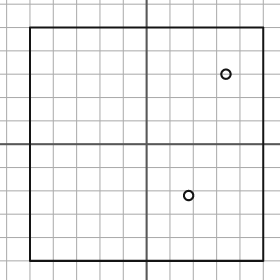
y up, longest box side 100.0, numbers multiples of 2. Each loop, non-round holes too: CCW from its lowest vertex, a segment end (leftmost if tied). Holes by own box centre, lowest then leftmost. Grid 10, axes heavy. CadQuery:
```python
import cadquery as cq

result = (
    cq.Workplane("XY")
    .moveTo(-50.0, -50.0)
    .lineTo(50.0, -50.0)
    .lineTo(50.0, 50.0)
    .lineTo(-50.0, 50.0)
    .close()
    .moveTo(18.0, -22.0)
    .circle(2.0)
    .moveTo(34.0, 30.0)
    .circle(2.0)
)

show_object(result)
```